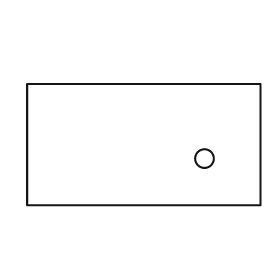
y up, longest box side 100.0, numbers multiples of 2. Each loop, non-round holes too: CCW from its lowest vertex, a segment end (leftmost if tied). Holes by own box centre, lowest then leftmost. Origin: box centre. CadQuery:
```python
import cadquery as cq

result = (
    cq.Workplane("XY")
    .moveTo(-50.0, -26.0)
    .lineTo(50.0, -26.0)
    .lineTo(50.0, 26.0)
    .lineTo(-50.0, 26.0)
    .close()
    .moveTo(26.0, -6.0)
    .circle(4.0)
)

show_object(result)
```